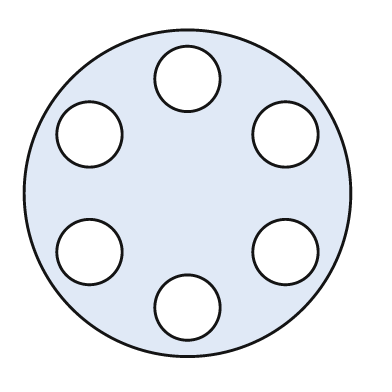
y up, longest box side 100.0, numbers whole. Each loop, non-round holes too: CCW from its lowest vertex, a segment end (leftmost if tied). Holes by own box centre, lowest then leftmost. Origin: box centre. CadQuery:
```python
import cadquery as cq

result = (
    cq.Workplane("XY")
    .moveTo(0.0, 0.0)
    .circle(50.0)
    .moveTo(0.0, -35.0)
    .circle(10.0)
    .moveTo(-30.0, -18.0)
    .circle(10.0)
    .moveTo(30.0, -18.0)
    .circle(10.0)
    .moveTo(-30.0, 18.0)
    .circle(10.0)
    .moveTo(30.0, 18.0)
    .circle(10.0)
    .moveTo(0.0, 35.0)
    .circle(10.0)
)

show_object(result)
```